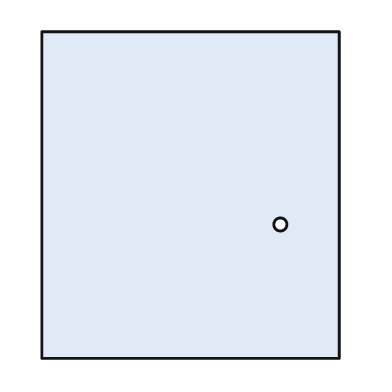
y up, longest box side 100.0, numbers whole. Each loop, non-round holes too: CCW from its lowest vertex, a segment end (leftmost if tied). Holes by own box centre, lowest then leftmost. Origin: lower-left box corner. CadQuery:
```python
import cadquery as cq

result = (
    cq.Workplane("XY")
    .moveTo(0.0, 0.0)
    .lineTo(91.0, 0.0)
    .lineTo(91.0, 100.0)
    .lineTo(0.0, 100.0)
    .close()
    .moveTo(73.0, 41.0)
    .circle(2.0)
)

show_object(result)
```